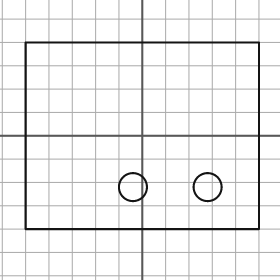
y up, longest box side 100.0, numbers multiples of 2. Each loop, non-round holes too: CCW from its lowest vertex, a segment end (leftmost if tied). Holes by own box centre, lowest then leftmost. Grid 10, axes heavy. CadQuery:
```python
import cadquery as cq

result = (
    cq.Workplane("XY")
    .moveTo(-50.0, -40.0)
    .lineTo(50.0, -40.0)
    .lineTo(50.0, 40.0)
    .lineTo(-50.0, 40.0)
    .close()
    .moveTo(-4.0, -22.0)
    .circle(6.0)
    .moveTo(28.0, -22.0)
    .circle(6.0)
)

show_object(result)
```